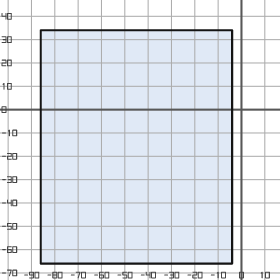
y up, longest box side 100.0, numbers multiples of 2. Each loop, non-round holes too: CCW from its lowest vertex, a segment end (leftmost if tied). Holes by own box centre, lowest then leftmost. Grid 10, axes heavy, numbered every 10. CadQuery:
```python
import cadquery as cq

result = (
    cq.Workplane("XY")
    .moveTo(-86.0, -66.0)
    .lineTo(-4.0, -66.0)
    .lineTo(-4.0, 34.0)
    .lineTo(-86.0, 34.0)
    .close()
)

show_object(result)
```